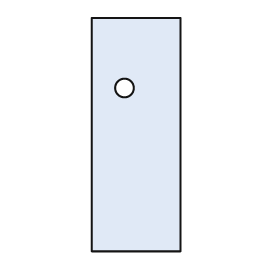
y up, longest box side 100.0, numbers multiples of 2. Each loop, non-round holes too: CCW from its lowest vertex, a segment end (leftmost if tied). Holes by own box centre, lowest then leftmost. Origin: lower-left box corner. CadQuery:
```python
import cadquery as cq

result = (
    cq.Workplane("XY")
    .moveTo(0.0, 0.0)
    .lineTo(38.0, 0.0)
    .lineTo(38.0, 100.0)
    .lineTo(0.0, 100.0)
    .close()
    .moveTo(14.0, 70.0)
    .circle(4.0)
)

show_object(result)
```